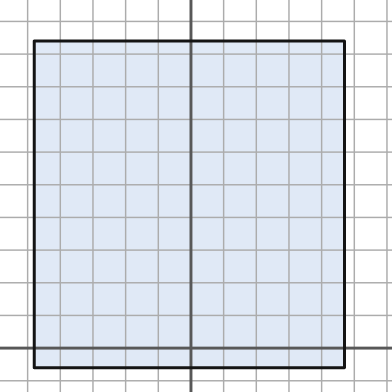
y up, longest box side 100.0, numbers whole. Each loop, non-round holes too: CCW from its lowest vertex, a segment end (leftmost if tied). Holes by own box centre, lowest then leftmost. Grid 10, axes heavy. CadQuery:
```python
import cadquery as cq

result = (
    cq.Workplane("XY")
    .moveTo(-48.0, -6.0)
    .lineTo(47.0, -6.0)
    .lineTo(47.0, 94.0)
    .lineTo(-48.0, 94.0)
    .close()
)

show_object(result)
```